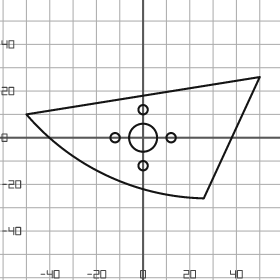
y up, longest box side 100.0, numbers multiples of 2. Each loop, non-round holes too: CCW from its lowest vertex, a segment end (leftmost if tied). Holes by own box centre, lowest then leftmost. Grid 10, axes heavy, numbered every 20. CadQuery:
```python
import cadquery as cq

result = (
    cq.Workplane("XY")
    .moveTo(26.0, -26.0)
    .lineTo(50.0, 26.0)
    .lineTo(-50.0, 10.0)
    .threePointArc((-16.0, -16.0), (26.0, -26.0))
    .close()
    .moveTo(0.0, -12.0)
    .circle(2.0)
    .moveTo(-12.0, 0.0)
    .circle(2.0)
    .moveTo(0.0, 0.0)
    .circle(6.0)
    .moveTo(12.0, 0.0)
    .circle(2.0)
    .moveTo(0.0, 12.0)
    .circle(2.0)
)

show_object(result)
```